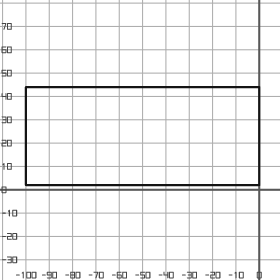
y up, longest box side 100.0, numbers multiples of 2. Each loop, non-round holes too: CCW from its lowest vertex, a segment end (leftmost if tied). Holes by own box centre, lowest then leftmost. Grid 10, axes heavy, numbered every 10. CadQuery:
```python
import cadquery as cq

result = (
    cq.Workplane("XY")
    .moveTo(-100.0, 2.0)
    .lineTo(0.0, 2.0)
    .lineTo(0.0, 44.0)
    .lineTo(-100.0, 44.0)
    .close()
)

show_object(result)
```